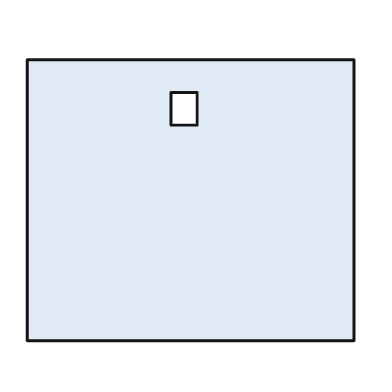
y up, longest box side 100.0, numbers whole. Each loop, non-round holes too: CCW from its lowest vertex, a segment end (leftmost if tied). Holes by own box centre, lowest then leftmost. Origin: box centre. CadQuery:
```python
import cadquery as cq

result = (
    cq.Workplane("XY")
    .moveTo(-50.0, -43.0)
    .lineTo(50.0, -43.0)
    .lineTo(50.0, 43.0)
    .lineTo(-50.0, 43.0)
    .close()
    .moveTo(-6.0, 23.0)
    .lineTo(2.0, 23.0)
    .lineTo(2.0, 33.0)
    .lineTo(-6.0, 33.0)
    .close()
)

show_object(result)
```